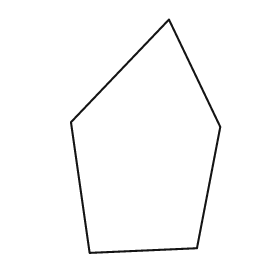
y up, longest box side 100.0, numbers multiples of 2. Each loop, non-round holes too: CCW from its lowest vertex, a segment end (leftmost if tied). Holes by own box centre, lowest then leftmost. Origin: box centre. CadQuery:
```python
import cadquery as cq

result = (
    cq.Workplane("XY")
    .moveTo(-24.0, -50.0)
    .lineTo(22.0, -48.0)
    .lineTo(32.0, 4.0)
    .lineTo(10.0, 50.0)
    .lineTo(-32.0, 6.0)
    .close()
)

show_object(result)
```